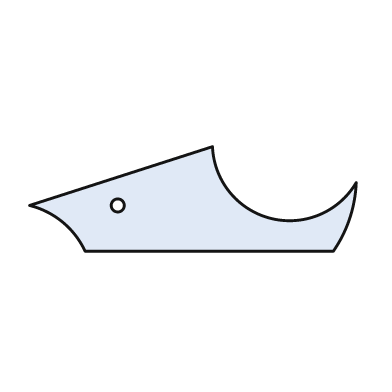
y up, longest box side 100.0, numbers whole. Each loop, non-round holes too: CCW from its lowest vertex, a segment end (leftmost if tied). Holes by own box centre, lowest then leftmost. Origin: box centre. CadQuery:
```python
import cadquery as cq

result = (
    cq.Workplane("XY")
    .moveTo(-33.0, -16.0)
    .lineTo(43.0, -16.0)
    .threePointArc((48.0, -6.0), (50.0, 5.0))
    .threePointArc((24.0, -6.0), (6.0, 16.0))
    .lineTo(-50.0, -2.0)
    .threePointArc((-40.0, -7.0), (-33.0, -16.0))
    .close()
    .moveTo(-23.0, -2.0)
    .circle(2.0)
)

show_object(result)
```